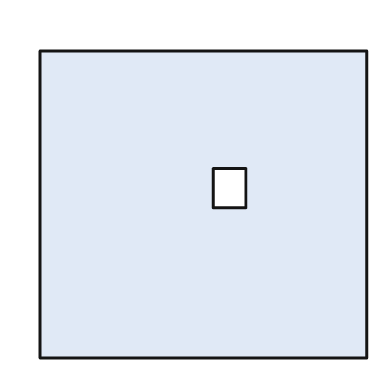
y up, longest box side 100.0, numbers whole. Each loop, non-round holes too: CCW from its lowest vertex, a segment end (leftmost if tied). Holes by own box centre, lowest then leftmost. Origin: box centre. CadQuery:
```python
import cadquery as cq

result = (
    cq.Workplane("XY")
    .moveTo(-50.0, -47.0)
    .lineTo(50.0, -47.0)
    .lineTo(50.0, 47.0)
    .lineTo(-50.0, 47.0)
    .close()
    .moveTo(3.0, -1.0)
    .lineTo(13.0, -1.0)
    .lineTo(13.0, 11.0)
    .lineTo(3.0, 11.0)
    .close()
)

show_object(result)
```